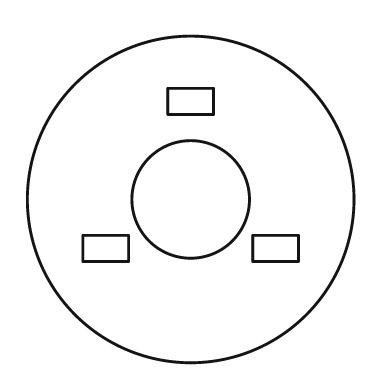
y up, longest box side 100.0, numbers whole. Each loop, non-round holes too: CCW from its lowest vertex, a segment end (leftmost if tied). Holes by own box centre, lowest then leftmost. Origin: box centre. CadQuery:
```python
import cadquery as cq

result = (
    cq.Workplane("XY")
    .moveTo(0.0, 0.0)
    .circle(50.0)
    .moveTo(-33.0, -19.0)
    .lineTo(-19.0, -19.0)
    .lineTo(-19.0, -11.0)
    .lineTo(-33.0, -11.0)
    .close()
    .moveTo(19.0, -19.0)
    .lineTo(33.0, -19.0)
    .lineTo(33.0, -11.0)
    .lineTo(19.0, -11.0)
    .close()
    .moveTo(0.0, 0.0)
    .circle(18.0)
    .moveTo(-7.0, 26.0)
    .lineTo(7.0, 26.0)
    .lineTo(7.0, 34.0)
    .lineTo(-7.0, 34.0)
    .close()
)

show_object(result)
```